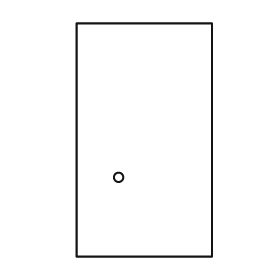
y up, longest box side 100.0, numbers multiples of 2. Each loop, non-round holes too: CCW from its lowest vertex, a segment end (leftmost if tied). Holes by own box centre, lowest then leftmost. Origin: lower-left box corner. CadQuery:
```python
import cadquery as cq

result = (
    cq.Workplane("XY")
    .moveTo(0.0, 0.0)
    .lineTo(58.0, 0.0)
    .lineTo(58.0, 100.0)
    .lineTo(0.0, 100.0)
    .close()
    .moveTo(18.0, 34.0)
    .circle(2.0)
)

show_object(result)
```